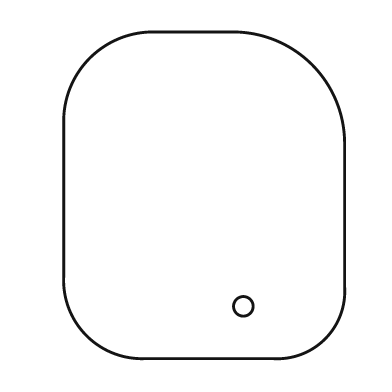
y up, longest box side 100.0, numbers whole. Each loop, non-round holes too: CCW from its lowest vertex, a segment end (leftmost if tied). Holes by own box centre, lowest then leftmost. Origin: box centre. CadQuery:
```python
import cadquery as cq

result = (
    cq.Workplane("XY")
    .moveTo(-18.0, -50.0)
    .lineTo(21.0, -50.0)
    .threePointArc((37.0, -44.0), (43.0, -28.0))
    .lineTo(43.0, 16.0)
    .threePointArc((33.0, 40.0), (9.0, 50.0))
    .lineTo(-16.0, 50.0)
    .threePointArc((-35.0, 42.0), (-43.0, 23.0))
    .lineTo(-43.0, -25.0)
    .threePointArc((-36.0, -43.0), (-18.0, -50.0))
    .close()
    .moveTo(12.0, -34.0)
    .circle(3.0)
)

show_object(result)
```